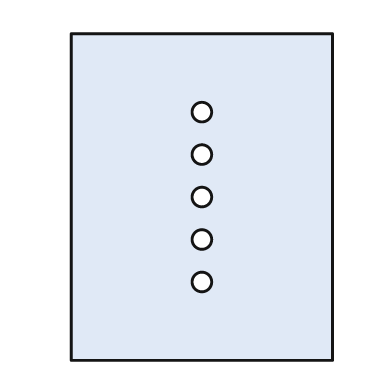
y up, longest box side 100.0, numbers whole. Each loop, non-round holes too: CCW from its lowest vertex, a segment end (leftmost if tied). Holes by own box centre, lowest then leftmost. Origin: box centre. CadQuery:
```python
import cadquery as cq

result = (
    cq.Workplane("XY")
    .moveTo(-40.0, -50.0)
    .lineTo(40.0, -50.0)
    .lineTo(40.0, 50.0)
    .lineTo(-40.0, 50.0)
    .close()
    .moveTo(0.0, -26.0)
    .circle(3.0)
    .moveTo(0.0, -13.0)
    .circle(3.0)
    .moveTo(0.0, 0.0)
    .circle(3.0)
    .moveTo(0.0, 13.0)
    .circle(3.0)
    .moveTo(0.0, 26.0)
    .circle(3.0)
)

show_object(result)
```